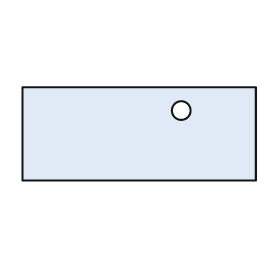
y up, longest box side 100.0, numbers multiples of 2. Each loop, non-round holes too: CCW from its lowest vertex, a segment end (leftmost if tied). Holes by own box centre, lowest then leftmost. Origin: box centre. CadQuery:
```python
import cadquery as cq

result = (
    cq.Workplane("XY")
    .moveTo(-50.0, -20.0)
    .lineTo(50.0, -20.0)
    .lineTo(50.0, 20.0)
    .lineTo(-50.0, 20.0)
    .close()
    .moveTo(18.0, 10.0)
    .circle(4.0)
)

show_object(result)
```